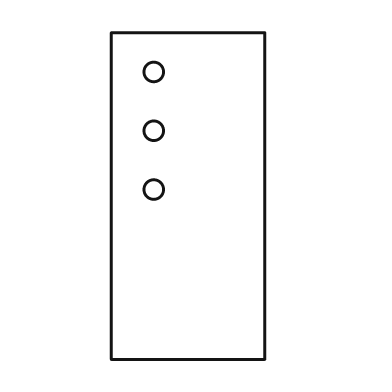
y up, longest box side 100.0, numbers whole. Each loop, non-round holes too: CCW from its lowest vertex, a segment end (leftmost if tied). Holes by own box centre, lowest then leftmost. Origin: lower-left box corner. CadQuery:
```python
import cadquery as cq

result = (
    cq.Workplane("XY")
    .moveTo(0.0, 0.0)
    .lineTo(47.0, 0.0)
    .lineTo(47.0, 100.0)
    .lineTo(0.0, 100.0)
    .close()
    .moveTo(13.0, 52.0)
    .circle(3.0)
    .moveTo(13.0, 70.0)
    .circle(3.0)
    .moveTo(13.0, 88.0)
    .circle(3.0)
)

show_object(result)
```